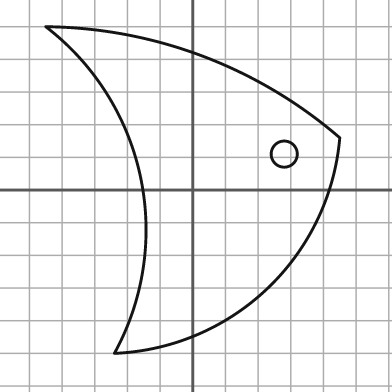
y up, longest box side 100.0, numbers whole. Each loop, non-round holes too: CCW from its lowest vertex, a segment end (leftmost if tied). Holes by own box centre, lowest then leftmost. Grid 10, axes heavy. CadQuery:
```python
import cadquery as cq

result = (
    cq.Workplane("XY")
    .moveTo(-24.0, -50.0)
    .threePointArc((23.0, -30.0), (45.0, 16.0))
    .threePointArc((3.0, 41.0), (-45.0, 50.0))
    .threePointArc((-16.0, 4.0), (-24.0, -50.0))
    .close()
    .moveTo(28.0, 11.0)
    .circle(4.0)
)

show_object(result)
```